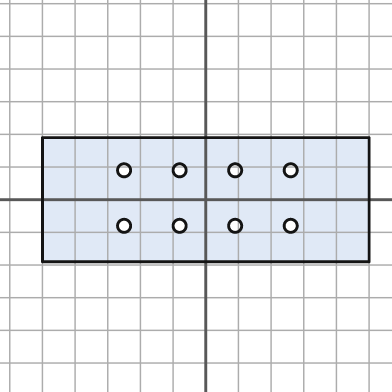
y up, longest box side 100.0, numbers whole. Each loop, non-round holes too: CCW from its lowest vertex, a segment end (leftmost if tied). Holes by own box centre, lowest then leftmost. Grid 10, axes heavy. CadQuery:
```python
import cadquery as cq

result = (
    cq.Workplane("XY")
    .moveTo(-50.0, -19.0)
    .lineTo(50.0, -19.0)
    .lineTo(50.0, 19.0)
    .lineTo(-50.0, 19.0)
    .close()
    .moveTo(-25.0, -8.0)
    .circle(2.0)
    .moveTo(-8.0, -8.0)
    .circle(2.0)
    .moveTo(9.0, -8.0)
    .circle(2.0)
    .moveTo(26.0, -8.0)
    .circle(2.0)
    .moveTo(-25.0, 9.0)
    .circle(2.0)
    .moveTo(-8.0, 9.0)
    .circle(2.0)
    .moveTo(9.0, 9.0)
    .circle(2.0)
    .moveTo(26.0, 9.0)
    .circle(2.0)
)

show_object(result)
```